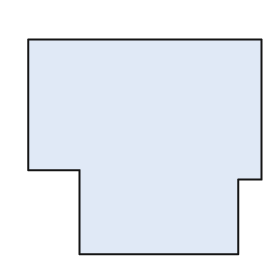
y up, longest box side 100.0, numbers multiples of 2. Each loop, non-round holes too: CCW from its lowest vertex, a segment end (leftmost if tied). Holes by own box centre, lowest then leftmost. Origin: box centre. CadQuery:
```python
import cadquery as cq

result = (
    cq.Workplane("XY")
    .moveTo(-28.0, -46.0)
    .lineTo(40.0, -46.0)
    .lineTo(40.0, -14.0)
    .lineTo(50.0, -14.0)
    .lineTo(50.0, 46.0)
    .lineTo(-50.0, 46.0)
    .lineTo(-50.0, -10.0)
    .lineTo(-28.0, -10.0)
    .close()
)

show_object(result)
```